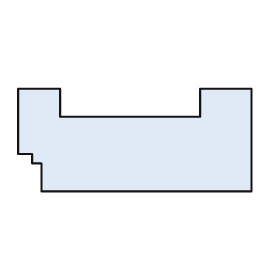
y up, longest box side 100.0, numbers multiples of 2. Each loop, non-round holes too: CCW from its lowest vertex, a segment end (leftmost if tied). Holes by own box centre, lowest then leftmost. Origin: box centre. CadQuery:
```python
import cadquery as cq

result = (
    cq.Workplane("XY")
    .moveTo(-40.0, -22.0)
    .lineTo(50.0, -22.0)
    .lineTo(50.0, 22.0)
    .lineTo(28.0, 22.0)
    .lineTo(28.0, 10.0)
    .lineTo(-32.0, 10.0)
    .lineTo(-32.0, 22.0)
    .lineTo(-50.0, 22.0)
    .lineTo(-50.0, -6.0)
    .lineTo(-44.0, -6.0)
    .lineTo(-44.0, -10.0)
    .lineTo(-40.0, -10.0)
    .close()
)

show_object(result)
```